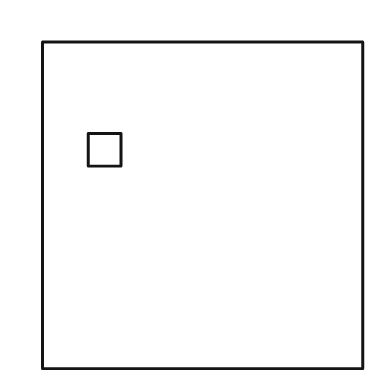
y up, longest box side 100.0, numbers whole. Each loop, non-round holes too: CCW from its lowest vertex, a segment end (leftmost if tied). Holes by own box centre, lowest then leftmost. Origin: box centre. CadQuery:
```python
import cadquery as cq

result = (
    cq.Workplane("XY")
    .moveTo(-49.0, -50.0)
    .lineTo(49.0, -50.0)
    .lineTo(49.0, 50.0)
    .lineTo(-49.0, 50.0)
    .close()
    .moveTo(-35.0, 12.0)
    .lineTo(-25.0, 12.0)
    .lineTo(-25.0, 22.0)
    .lineTo(-35.0, 22.0)
    .close()
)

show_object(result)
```